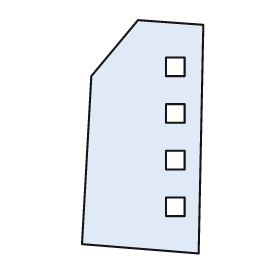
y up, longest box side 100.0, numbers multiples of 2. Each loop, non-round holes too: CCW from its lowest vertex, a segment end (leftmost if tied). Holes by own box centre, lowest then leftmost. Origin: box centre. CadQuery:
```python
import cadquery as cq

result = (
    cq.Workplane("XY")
    .moveTo(24.0, -50.0)
    .lineTo(26.0, 48.0)
    .lineTo(-2.0, 50.0)
    .lineTo(-22.0, 26.0)
    .lineTo(-26.0, -46.0)
    .close()
    .moveTo(10.0, -34.0)
    .lineTo(18.0, -34.0)
    .lineTo(18.0, -26.0)
    .lineTo(10.0, -26.0)
    .close()
    .moveTo(10.0, -14.0)
    .lineTo(18.0, -14.0)
    .lineTo(18.0, -6.0)
    .lineTo(10.0, -6.0)
    .close()
    .moveTo(10.0, 6.0)
    .lineTo(18.0, 6.0)
    .lineTo(18.0, 14.0)
    .lineTo(10.0, 14.0)
    .close()
    .moveTo(10.0, 26.0)
    .lineTo(18.0, 26.0)
    .lineTo(18.0, 34.0)
    .lineTo(10.0, 34.0)
    .close()
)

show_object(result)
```